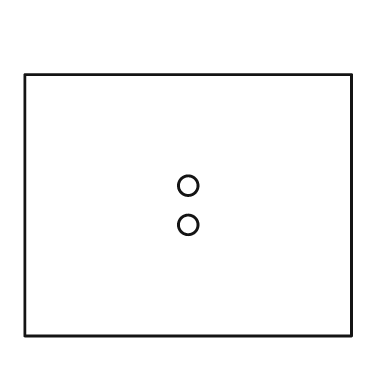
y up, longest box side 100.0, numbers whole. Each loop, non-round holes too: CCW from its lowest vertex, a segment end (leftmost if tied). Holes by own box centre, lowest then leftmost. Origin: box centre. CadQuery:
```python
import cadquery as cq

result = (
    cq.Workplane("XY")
    .moveTo(-50.0, -40.0)
    .lineTo(50.0, -40.0)
    .lineTo(50.0, 40.0)
    .lineTo(-50.0, 40.0)
    .close()
    .moveTo(0.0, -6.0)
    .circle(3.0)
    .moveTo(0.0, 6.0)
    .circle(3.0)
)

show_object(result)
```